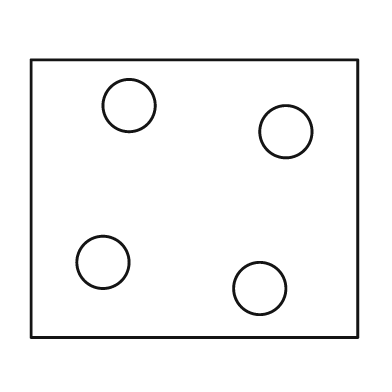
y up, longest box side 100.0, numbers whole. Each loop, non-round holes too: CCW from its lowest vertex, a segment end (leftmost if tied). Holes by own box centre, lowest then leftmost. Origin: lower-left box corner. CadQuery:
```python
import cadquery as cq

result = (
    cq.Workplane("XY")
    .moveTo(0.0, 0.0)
    .lineTo(100.0, 0.0)
    .lineTo(100.0, 85.0)
    .lineTo(0.0, 85.0)
    .close()
    .moveTo(70.0, 15.0)
    .circle(8.0)
    .moveTo(22.0, 23.0)
    .circle(8.0)
    .moveTo(78.0, 63.0)
    .circle(8.0)
    .moveTo(30.0, 71.0)
    .circle(8.0)
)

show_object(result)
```